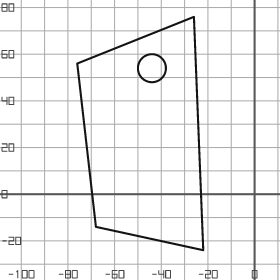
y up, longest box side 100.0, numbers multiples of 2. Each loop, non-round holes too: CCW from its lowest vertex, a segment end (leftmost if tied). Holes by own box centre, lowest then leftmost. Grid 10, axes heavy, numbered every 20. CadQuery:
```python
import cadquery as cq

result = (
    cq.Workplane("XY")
    .moveTo(-22.0, -24.0)
    .lineTo(-26.0, 76.0)
    .lineTo(-76.0, 56.0)
    .lineTo(-68.0, -14.0)
    .close()
    .moveTo(-44.0, 54.0)
    .circle(6.0)
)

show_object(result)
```